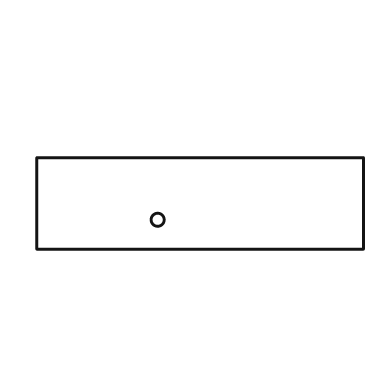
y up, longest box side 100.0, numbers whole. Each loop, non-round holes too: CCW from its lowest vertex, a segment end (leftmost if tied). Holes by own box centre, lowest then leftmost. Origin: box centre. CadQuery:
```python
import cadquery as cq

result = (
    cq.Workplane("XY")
    .moveTo(-50.0, -14.0)
    .lineTo(50.0, -14.0)
    .lineTo(50.0, 14.0)
    .lineTo(-50.0, 14.0)
    .close()
    .moveTo(-13.0, -5.0)
    .circle(2.0)
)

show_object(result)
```